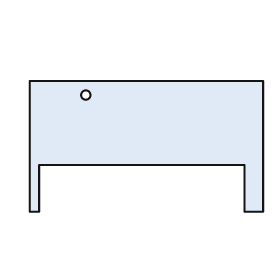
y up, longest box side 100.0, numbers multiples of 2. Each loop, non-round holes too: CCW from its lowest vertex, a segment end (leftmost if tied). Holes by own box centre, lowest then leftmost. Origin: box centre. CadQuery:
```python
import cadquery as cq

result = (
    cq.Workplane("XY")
    .moveTo(-50.0, -28.0)
    .lineTo(-46.0, -28.0)
    .lineTo(-46.0, -8.0)
    .lineTo(42.0, -8.0)
    .lineTo(42.0, -28.0)
    .lineTo(50.0, -28.0)
    .lineTo(50.0, 28.0)
    .lineTo(-50.0, 28.0)
    .close()
    .moveTo(-26.0, 22.0)
    .circle(2.0)
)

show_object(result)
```